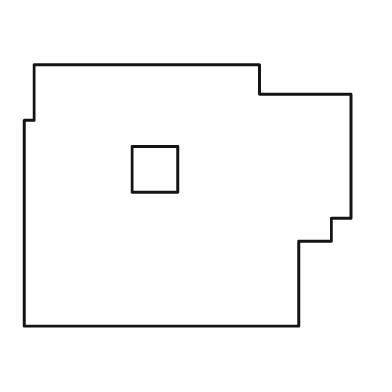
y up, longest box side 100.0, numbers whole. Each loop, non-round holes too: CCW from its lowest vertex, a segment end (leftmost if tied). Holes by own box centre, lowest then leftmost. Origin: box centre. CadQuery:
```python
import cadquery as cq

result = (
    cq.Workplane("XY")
    .moveTo(-50.0, -40.0)
    .lineTo(34.0, -40.0)
    .lineTo(34.0, -14.0)
    .lineTo(44.0, -14.0)
    .lineTo(44.0, -7.0)
    .lineTo(50.0, -7.0)
    .lineTo(50.0, 31.0)
    .lineTo(22.0, 31.0)
    .lineTo(22.0, 40.0)
    .lineTo(-47.0, 40.0)
    .lineTo(-47.0, 23.0)
    .lineTo(-50.0, 23.0)
    .close()
    .moveTo(-17.0, 1.0)
    .lineTo(-3.0, 1.0)
    .lineTo(-3.0, 15.0)
    .lineTo(-17.0, 15.0)
    .close()
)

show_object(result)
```